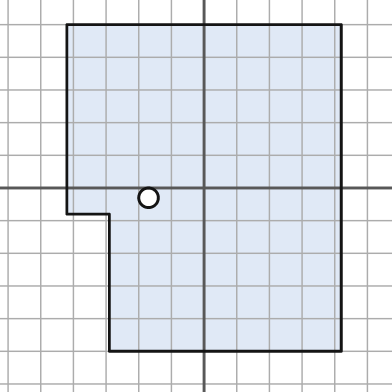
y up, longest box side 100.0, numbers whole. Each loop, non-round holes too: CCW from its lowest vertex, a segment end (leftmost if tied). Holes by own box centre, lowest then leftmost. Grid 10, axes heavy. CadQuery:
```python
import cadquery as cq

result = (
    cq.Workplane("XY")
    .moveTo(-29.0, -50.0)
    .lineTo(42.0, -50.0)
    .lineTo(42.0, 50.0)
    .lineTo(-42.0, 50.0)
    .lineTo(-42.0, -8.0)
    .lineTo(-29.0, -8.0)
    .close()
    .moveTo(-17.0, -3.0)
    .circle(3.0)
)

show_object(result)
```